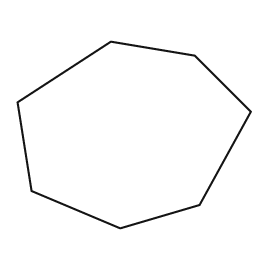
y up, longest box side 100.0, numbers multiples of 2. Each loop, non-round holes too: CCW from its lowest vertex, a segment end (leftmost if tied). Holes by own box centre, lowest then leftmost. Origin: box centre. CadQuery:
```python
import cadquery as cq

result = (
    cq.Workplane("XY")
    .moveTo(-6.0, -40.0)
    .lineTo(28.0, -30.0)
    .lineTo(50.0, 10.0)
    .lineTo(26.0, 34.0)
    .lineTo(-10.0, 40.0)
    .lineTo(-50.0, 14.0)
    .lineTo(-44.0, -24.0)
    .close()
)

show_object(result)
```